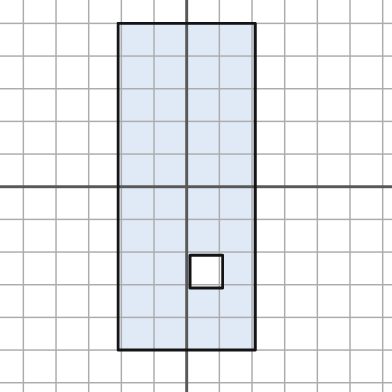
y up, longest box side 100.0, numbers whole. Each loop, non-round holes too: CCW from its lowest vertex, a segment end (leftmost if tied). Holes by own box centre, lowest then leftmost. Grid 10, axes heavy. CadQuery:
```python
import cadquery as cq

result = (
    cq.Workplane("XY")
    .moveTo(-21.0, -50.0)
    .lineTo(21.0, -50.0)
    .lineTo(21.0, 50.0)
    .lineTo(-21.0, 50.0)
    .close()
    .moveTo(1.0, -31.0)
    .lineTo(11.0, -31.0)
    .lineTo(11.0, -21.0)
    .lineTo(1.0, -21.0)
    .close()
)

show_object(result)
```